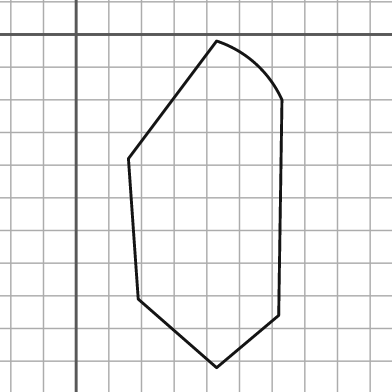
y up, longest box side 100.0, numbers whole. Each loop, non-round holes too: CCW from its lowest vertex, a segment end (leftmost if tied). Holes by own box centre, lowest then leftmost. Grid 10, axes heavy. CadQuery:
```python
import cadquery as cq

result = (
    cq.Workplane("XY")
    .moveTo(43.0, -102.0)
    .lineTo(62.0, -86.0)
    .lineTo(63.0, -20.0)
    .threePointArc((55.0, -9.0), (43.0, -2.0))
    .lineTo(16.0, -38.0)
    .lineTo(19.0, -81.0)
    .close()
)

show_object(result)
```